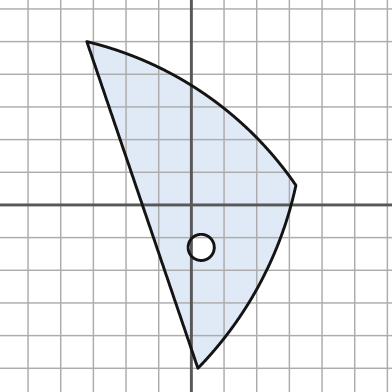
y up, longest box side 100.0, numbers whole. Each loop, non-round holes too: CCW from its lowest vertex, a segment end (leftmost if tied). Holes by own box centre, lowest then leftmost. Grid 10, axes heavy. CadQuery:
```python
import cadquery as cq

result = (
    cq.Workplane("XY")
    .moveTo(2.0, -50.0)
    .threePointArc((21.0, -24.0), (32.0, 6.0))
    .threePointArc((4.0, 34.0), (-32.0, 50.0))
    .close()
    .moveTo(3.0, -13.0)
    .circle(4.0)
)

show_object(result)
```